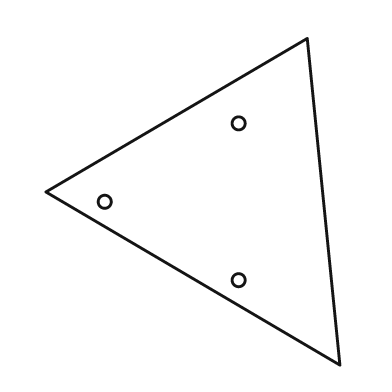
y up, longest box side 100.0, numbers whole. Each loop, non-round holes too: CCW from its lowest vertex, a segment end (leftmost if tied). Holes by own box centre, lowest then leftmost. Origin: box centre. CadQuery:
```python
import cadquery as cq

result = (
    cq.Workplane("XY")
    .moveTo(45.0, -50.0)
    .lineTo(35.0, 50.0)
    .lineTo(-45.0, 3.0)
    .close()
    .moveTo(14.0, -24.0)
    .circle(2.0)
    .moveTo(-27.0, 0.0)
    .circle(2.0)
    .moveTo(14.0, 24.0)
    .circle(2.0)
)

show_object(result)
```